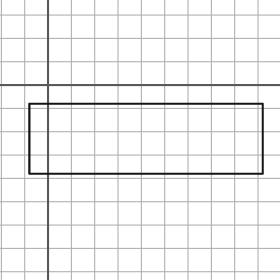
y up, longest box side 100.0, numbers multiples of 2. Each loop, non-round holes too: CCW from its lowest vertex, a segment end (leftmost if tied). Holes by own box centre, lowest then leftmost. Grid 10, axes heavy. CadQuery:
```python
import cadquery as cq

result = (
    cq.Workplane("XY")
    .moveTo(-8.0, -38.0)
    .lineTo(92.0, -38.0)
    .lineTo(92.0, -8.0)
    .lineTo(-8.0, -8.0)
    .close()
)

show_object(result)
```